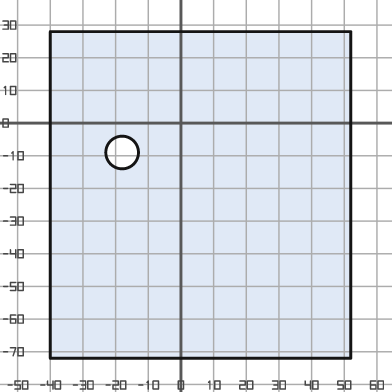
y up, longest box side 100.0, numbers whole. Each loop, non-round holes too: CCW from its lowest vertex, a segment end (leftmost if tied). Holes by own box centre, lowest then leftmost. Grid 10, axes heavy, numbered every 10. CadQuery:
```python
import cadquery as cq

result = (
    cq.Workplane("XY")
    .moveTo(-40.0, -72.0)
    .lineTo(52.0, -72.0)
    .lineTo(52.0, 28.0)
    .lineTo(-40.0, 28.0)
    .close()
    .moveTo(-18.0, -9.0)
    .circle(5.0)
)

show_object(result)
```